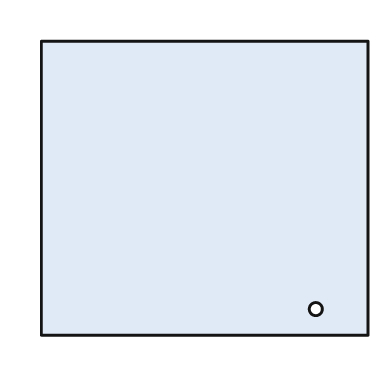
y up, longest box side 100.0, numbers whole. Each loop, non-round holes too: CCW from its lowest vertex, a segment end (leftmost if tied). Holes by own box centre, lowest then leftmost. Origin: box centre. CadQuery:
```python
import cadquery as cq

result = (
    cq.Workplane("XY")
    .moveTo(-50.0, -45.0)
    .lineTo(50.0, -45.0)
    .lineTo(50.0, 45.0)
    .lineTo(-50.0, 45.0)
    .close()
    .moveTo(34.0, -37.0)
    .circle(2.0)
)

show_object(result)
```